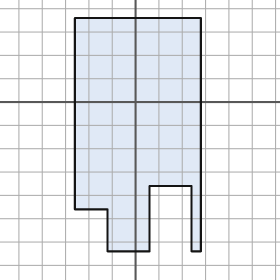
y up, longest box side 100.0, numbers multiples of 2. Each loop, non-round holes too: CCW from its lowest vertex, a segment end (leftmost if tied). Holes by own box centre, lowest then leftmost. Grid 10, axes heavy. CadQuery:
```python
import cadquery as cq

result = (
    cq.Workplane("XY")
    .moveTo(-12.0, -64.0)
    .lineTo(6.0, -64.0)
    .lineTo(6.0, -36.0)
    .lineTo(24.0, -36.0)
    .lineTo(24.0, -64.0)
    .lineTo(28.0, -64.0)
    .lineTo(28.0, 36.0)
    .lineTo(-26.0, 36.0)
    .lineTo(-26.0, -46.0)
    .lineTo(-12.0, -46.0)
    .close()
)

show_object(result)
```